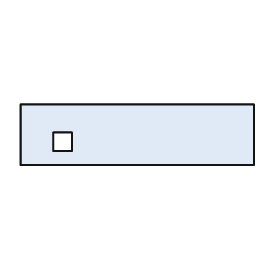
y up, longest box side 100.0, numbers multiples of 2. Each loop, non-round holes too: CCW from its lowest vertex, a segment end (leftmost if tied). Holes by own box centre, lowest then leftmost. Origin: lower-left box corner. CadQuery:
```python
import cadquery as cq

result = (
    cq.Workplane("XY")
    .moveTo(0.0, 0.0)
    .lineTo(100.0, 0.0)
    .lineTo(100.0, 26.0)
    .lineTo(0.0, 26.0)
    .close()
    .moveTo(14.0, 6.0)
    .lineTo(22.0, 6.0)
    .lineTo(22.0, 14.0)
    .lineTo(14.0, 14.0)
    .close()
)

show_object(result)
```